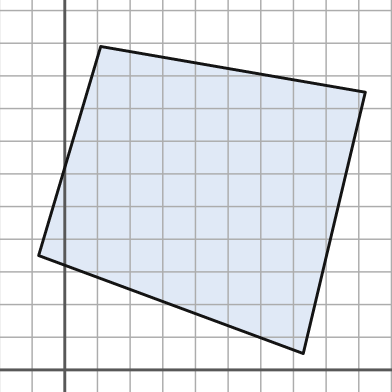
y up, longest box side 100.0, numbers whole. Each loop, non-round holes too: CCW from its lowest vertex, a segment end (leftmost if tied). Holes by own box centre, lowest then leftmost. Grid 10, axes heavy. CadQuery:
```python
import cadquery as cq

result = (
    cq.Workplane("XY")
    .moveTo(73.0, 5.0)
    .lineTo(92.0, 85.0)
    .lineTo(11.0, 99.0)
    .lineTo(-8.0, 35.0)
    .close()
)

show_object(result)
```